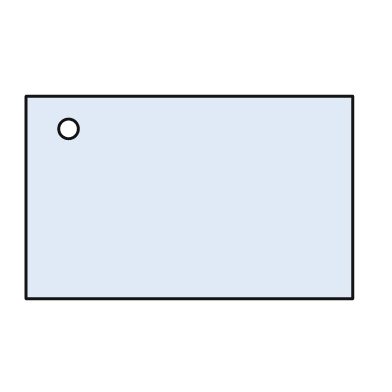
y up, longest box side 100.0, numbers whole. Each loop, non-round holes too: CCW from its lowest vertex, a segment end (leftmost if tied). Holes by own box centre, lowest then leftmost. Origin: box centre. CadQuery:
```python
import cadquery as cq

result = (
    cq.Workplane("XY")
    .moveTo(-50.0, -31.0)
    .lineTo(50.0, -31.0)
    .lineTo(50.0, 31.0)
    .lineTo(-50.0, 31.0)
    .close()
    .moveTo(-37.0, 21.0)
    .circle(3.0)
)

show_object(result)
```